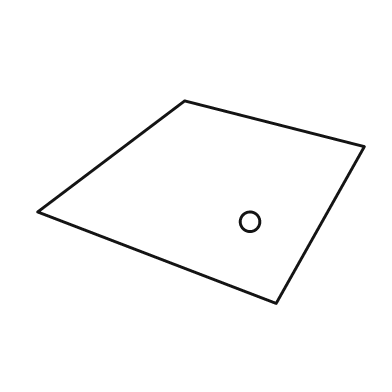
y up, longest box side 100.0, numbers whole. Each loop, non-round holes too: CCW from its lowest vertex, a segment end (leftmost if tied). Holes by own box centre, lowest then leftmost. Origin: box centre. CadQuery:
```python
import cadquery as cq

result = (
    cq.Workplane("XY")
    .moveTo(23.0, -31.0)
    .lineTo(50.0, 17.0)
    .lineTo(-5.0, 31.0)
    .lineTo(-50.0, -3.0)
    .close()
    .moveTo(15.0, -6.0)
    .circle(3.0)
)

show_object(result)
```